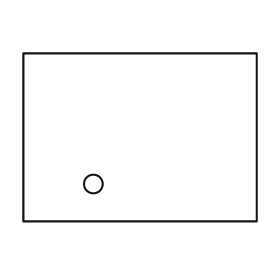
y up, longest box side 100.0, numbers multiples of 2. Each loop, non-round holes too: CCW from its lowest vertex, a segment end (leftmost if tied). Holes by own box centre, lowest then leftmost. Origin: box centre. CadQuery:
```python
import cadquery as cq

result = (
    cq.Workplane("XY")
    .moveTo(-50.0, -36.0)
    .lineTo(50.0, -36.0)
    .lineTo(50.0, 36.0)
    .lineTo(-50.0, 36.0)
    .close()
    .moveTo(-20.0, -20.0)
    .circle(4.0)
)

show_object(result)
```